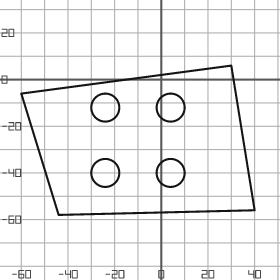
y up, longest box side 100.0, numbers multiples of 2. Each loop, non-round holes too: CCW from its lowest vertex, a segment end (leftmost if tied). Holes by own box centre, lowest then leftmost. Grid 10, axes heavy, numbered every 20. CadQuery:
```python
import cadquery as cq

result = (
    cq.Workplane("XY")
    .moveTo(-44.0, -58.0)
    .lineTo(40.0, -56.0)
    .lineTo(30.0, 6.0)
    .lineTo(-60.0, -6.0)
    .close()
    .moveTo(-24.0, -40.0)
    .circle(6.0)
    .moveTo(4.0, -40.0)
    .circle(6.0)
    .moveTo(-24.0, -12.0)
    .circle(6.0)
    .moveTo(4.0, -12.0)
    .circle(6.0)
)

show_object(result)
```